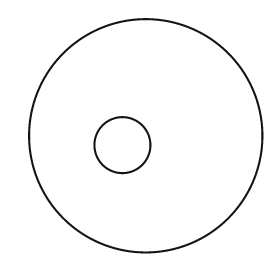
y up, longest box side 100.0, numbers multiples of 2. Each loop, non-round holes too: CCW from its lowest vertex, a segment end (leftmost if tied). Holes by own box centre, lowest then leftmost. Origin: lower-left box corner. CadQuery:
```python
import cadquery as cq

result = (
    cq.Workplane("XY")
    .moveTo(50.0, 50.0)
    .circle(50.0)
    .moveTo(40.0, 46.0)
    .circle(12.0)
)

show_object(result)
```